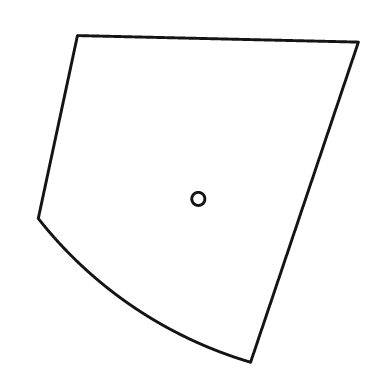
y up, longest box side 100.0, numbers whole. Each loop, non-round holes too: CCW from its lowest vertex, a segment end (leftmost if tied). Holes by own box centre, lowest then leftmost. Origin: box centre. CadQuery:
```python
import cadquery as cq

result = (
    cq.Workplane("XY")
    .moveTo(16.0, -50.0)
    .lineTo(49.0, 48.0)
    .lineTo(-37.0, 50.0)
    .lineTo(-49.0, -6.0)
    .threePointArc((-20.0, -33.0), (16.0, -50.0))
    .close()
    .moveTo(0.0, 0.0)
    .circle(2.0)
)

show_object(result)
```